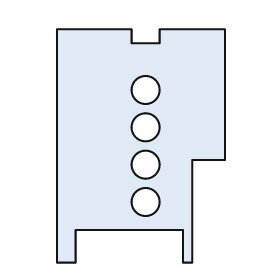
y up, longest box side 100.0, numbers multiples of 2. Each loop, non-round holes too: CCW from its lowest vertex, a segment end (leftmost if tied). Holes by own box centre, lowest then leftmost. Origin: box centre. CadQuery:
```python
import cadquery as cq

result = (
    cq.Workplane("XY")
    .moveTo(-36.0, -50.0)
    .lineTo(-28.0, -50.0)
    .lineTo(-28.0, -36.0)
    .lineTo(18.0, -36.0)
    .lineTo(18.0, -50.0)
    .lineTo(22.0, -50.0)
    .lineTo(22.0, -6.0)
    .lineTo(36.0, -6.0)
    .lineTo(36.0, 50.0)
    .lineTo(8.0, 50.0)
    .lineTo(8.0, 44.0)
    .lineTo(-4.0, 44.0)
    .lineTo(-4.0, 50.0)
    .lineTo(-36.0, 50.0)
    .close()
    .moveTo(2.0, -24.0)
    .circle(6.0)
    .moveTo(2.0, -8.0)
    .circle(6.0)
    .moveTo(2.0, 8.0)
    .circle(6.0)
    .moveTo(2.0, 24.0)
    .circle(6.0)
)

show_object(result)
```